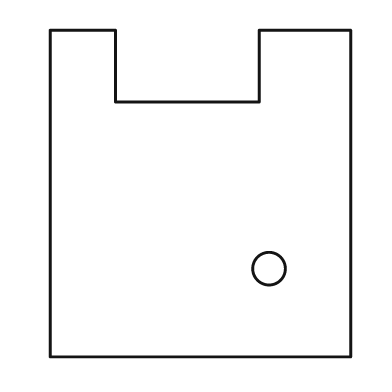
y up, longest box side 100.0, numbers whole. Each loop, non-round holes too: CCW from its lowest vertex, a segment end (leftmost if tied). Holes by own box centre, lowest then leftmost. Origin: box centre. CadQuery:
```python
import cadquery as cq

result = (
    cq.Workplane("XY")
    .moveTo(-46.0, -50.0)
    .lineTo(46.0, -50.0)
    .lineTo(46.0, 50.0)
    .lineTo(18.0, 50.0)
    .lineTo(18.0, 28.0)
    .lineTo(-26.0, 28.0)
    .lineTo(-26.0, 50.0)
    .lineTo(-46.0, 50.0)
    .close()
    .moveTo(21.0, -23.0)
    .circle(5.0)
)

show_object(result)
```